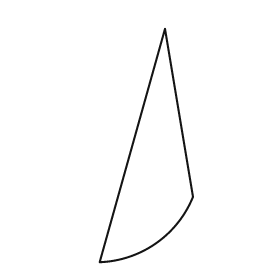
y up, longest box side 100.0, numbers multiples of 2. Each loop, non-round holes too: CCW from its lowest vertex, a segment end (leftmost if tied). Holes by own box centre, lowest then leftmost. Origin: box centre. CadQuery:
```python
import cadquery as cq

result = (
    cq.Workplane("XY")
    .moveTo(-20.0, -50.0)
    .threePointArc((4.0, -42.0), (20.0, -22.0))
    .lineTo(8.0, 50.0)
    .close()
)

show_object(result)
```